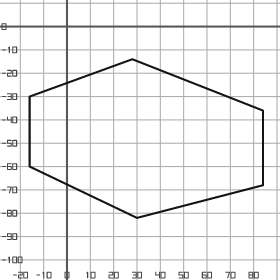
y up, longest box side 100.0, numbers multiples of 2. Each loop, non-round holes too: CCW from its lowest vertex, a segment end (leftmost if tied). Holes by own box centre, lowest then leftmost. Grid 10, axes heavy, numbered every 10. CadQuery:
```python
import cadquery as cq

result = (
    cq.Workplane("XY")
    .moveTo(30.0, -82.0)
    .lineTo(84.0, -68.0)
    .lineTo(84.0, -36.0)
    .lineTo(28.0, -14.0)
    .lineTo(-16.0, -30.0)
    .lineTo(-16.0, -60.0)
    .close()
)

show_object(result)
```